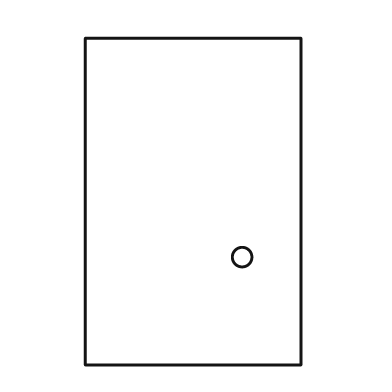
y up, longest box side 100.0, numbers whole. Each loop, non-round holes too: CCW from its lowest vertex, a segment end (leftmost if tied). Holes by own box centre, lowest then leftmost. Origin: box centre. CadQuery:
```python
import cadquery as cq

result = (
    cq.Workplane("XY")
    .moveTo(-33.0, -50.0)
    .lineTo(33.0, -50.0)
    .lineTo(33.0, 50.0)
    .lineTo(-33.0, 50.0)
    .close()
    .moveTo(15.0, -17.0)
    .circle(3.0)
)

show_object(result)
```